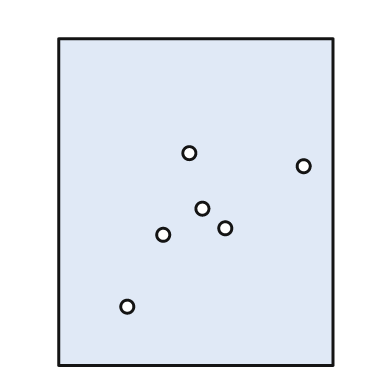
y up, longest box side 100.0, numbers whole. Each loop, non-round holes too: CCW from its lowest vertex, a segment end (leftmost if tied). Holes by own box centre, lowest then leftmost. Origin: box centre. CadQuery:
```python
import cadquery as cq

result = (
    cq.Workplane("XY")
    .moveTo(-42.0, -50.0)
    .lineTo(42.0, -50.0)
    .lineTo(42.0, 50.0)
    .lineTo(-42.0, 50.0)
    .close()
    .moveTo(-21.0, -32.0)
    .circle(2.0)
    .moveTo(-10.0, -10.0)
    .circle(2.0)
    .moveTo(9.0, -8.0)
    .circle(2.0)
    .moveTo(2.0, -2.0)
    .circle(2.0)
    .moveTo(33.0, 11.0)
    .circle(2.0)
    .moveTo(-2.0, 15.0)
    .circle(2.0)
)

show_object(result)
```